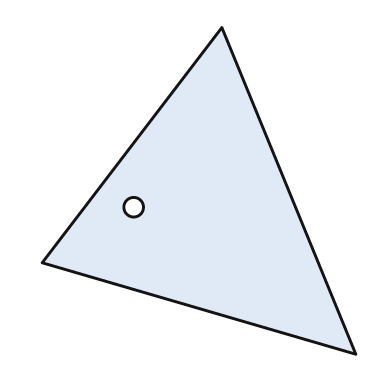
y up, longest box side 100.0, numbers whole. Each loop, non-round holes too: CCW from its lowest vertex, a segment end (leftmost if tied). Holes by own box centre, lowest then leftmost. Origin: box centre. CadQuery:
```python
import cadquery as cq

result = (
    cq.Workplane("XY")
    .moveTo(48.0, -50.0)
    .lineTo(7.0, 50.0)
    .lineTo(-48.0, -22.0)
    .close()
    .moveTo(-20.0, -5.0)
    .circle(3.0)
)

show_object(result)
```